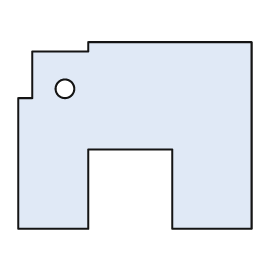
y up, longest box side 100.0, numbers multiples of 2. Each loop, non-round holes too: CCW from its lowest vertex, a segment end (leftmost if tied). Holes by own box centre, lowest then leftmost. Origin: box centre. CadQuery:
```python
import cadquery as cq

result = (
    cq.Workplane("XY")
    .moveTo(-50.0, -40.0)
    .lineTo(-20.0, -40.0)
    .lineTo(-20.0, -6.0)
    .lineTo(16.0, -6.0)
    .lineTo(16.0, -40.0)
    .lineTo(50.0, -40.0)
    .lineTo(50.0, 40.0)
    .lineTo(-20.0, 40.0)
    .lineTo(-20.0, 36.0)
    .lineTo(-44.0, 36.0)
    .lineTo(-44.0, 16.0)
    .lineTo(-50.0, 16.0)
    .close()
    .moveTo(-30.0, 20.0)
    .circle(4.0)
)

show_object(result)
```